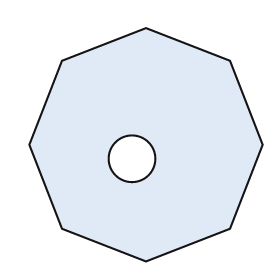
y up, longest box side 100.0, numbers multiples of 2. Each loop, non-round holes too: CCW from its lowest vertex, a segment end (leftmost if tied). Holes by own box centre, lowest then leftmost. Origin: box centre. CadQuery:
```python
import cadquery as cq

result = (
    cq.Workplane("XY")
    .moveTo(0.0, -50.0)
    .lineTo(36.0, -36.0)
    .lineTo(50.0, 0.0)
    .lineTo(36.0, 36.0)
    .lineTo(0.0, 50.0)
    .lineTo(-36.0, 36.0)
    .lineTo(-50.0, 0.0)
    .lineTo(-36.0, -36.0)
    .close()
    .moveTo(-6.0, -6.0)
    .circle(10.0)
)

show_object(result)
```